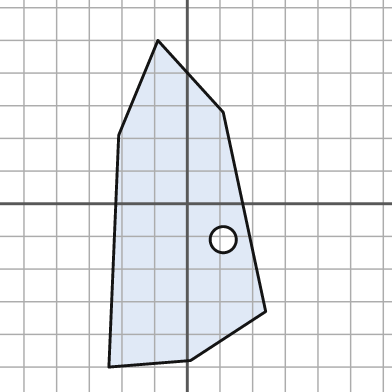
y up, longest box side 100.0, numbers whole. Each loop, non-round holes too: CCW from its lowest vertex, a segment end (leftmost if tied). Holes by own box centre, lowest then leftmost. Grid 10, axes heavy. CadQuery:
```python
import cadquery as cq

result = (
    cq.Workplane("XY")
    .moveTo(-24.0, -50.0)
    .lineTo(1.0, -48.0)
    .lineTo(24.0, -33.0)
    .lineTo(11.0, 28.0)
    .lineTo(-9.0, 50.0)
    .lineTo(-21.0, 21.0)
    .close()
    .moveTo(11.0, -11.0)
    .circle(4.0)
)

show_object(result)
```